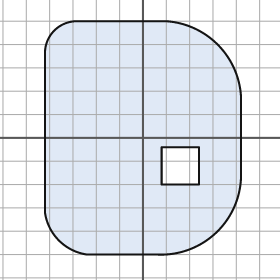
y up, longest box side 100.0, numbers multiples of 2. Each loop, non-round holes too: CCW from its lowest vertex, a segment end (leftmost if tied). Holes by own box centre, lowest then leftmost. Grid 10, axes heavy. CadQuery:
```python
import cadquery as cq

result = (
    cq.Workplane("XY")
    .moveTo(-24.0, -50.0)
    .lineTo(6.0, -50.0)
    .threePointArc((32.0, -40.0), (42.0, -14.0))
    .lineTo(42.0, 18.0)
    .threePointArc((32.0, 40.0), (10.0, 50.0))
    .lineTo(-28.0, 50.0)
    .threePointArc((-38.0, 46.0), (-42.0, 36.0))
    .lineTo(-42.0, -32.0)
    .threePointArc((-36.0, -44.0), (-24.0, -50.0))
    .close()
    .moveTo(8.0, -20.0)
    .lineTo(24.0, -20.0)
    .lineTo(24.0, -4.0)
    .lineTo(8.0, -4.0)
    .close()
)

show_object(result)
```